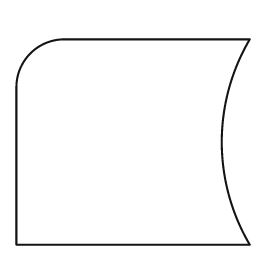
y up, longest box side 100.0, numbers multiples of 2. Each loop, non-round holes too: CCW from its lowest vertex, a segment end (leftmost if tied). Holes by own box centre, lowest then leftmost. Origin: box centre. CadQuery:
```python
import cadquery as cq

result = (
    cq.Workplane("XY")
    .moveTo(-50.0, -44.0)
    .lineTo(50.0, -44.0)
    .threePointArc((38.0, 0.0), (50.0, 44.0))
    .lineTo(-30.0, 44.0)
    .threePointArc((-44.0, 38.0), (-50.0, 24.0))
    .close()
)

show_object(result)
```